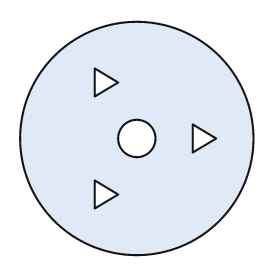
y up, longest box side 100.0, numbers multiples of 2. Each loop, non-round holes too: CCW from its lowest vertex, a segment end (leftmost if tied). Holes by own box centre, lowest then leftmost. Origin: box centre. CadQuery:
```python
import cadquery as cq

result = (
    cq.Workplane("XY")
    .moveTo(0.0, 0.0)
    .circle(50.0)
    .moveTo(-18.0, -30.0)
    .lineTo(-8.0, -24.0)
    .lineTo(-18.0, -18.0)
    .close()
    .moveTo(0.0, 0.0)
    .circle(8.0)
    .moveTo(24.0, -6.0)
    .lineTo(34.0, 0.0)
    .lineTo(24.0, 6.0)
    .close()
    .moveTo(-18.0, 18.0)
    .lineTo(-8.0, 24.0)
    .lineTo(-18.0, 30.0)
    .close()
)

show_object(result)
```